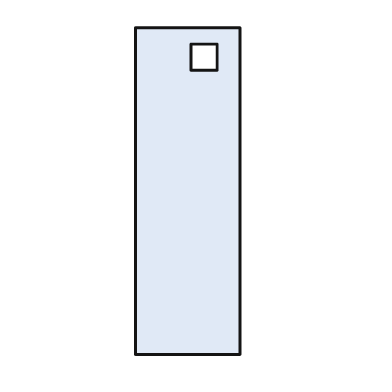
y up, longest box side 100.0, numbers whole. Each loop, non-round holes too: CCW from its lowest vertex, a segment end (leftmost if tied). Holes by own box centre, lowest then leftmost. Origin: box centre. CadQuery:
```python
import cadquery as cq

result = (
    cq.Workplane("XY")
    .moveTo(-16.0, -50.0)
    .lineTo(16.0, -50.0)
    .lineTo(16.0, 50.0)
    .lineTo(-16.0, 50.0)
    .close()
    .moveTo(1.0, 37.0)
    .lineTo(9.0, 37.0)
    .lineTo(9.0, 45.0)
    .lineTo(1.0, 45.0)
    .close()
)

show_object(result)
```